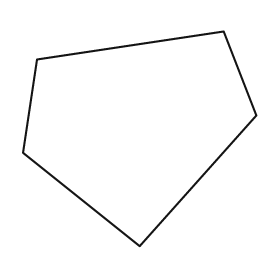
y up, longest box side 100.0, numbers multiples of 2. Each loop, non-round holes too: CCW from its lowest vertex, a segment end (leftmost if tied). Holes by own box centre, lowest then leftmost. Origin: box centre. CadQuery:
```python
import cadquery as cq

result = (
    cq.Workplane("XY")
    .moveTo(0.0, -46.0)
    .lineTo(50.0, 10.0)
    .lineTo(36.0, 46.0)
    .lineTo(-44.0, 34.0)
    .lineTo(-50.0, -6.0)
    .close()
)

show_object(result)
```